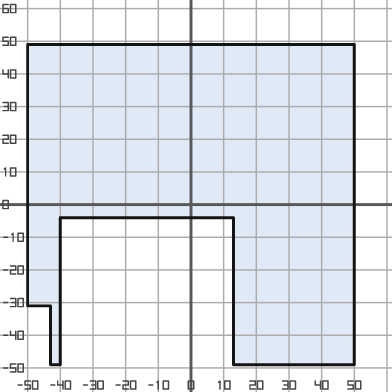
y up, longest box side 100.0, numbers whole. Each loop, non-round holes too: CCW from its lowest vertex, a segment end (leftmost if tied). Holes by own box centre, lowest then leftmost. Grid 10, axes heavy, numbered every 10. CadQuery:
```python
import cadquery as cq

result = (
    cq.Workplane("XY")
    .moveTo(-43.0, -49.0)
    .lineTo(-40.0, -49.0)
    .lineTo(-40.0, -4.0)
    .lineTo(13.0, -4.0)
    .lineTo(13.0, -49.0)
    .lineTo(50.0, -49.0)
    .lineTo(50.0, 49.0)
    .lineTo(-50.0, 49.0)
    .lineTo(-50.0, -31.0)
    .lineTo(-43.0, -31.0)
    .close()
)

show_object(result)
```